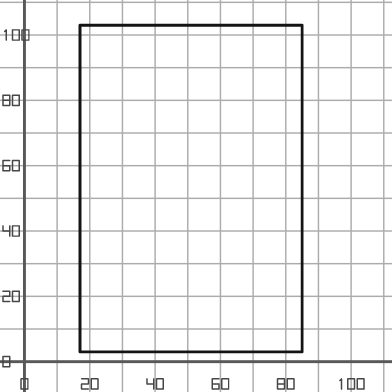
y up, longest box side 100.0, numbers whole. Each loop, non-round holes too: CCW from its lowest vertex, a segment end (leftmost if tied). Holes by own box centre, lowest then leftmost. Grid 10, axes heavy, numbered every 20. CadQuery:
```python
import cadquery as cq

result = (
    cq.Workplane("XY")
    .moveTo(17.0, 3.0)
    .lineTo(85.0, 3.0)
    .lineTo(85.0, 103.0)
    .lineTo(17.0, 103.0)
    .close()
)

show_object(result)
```